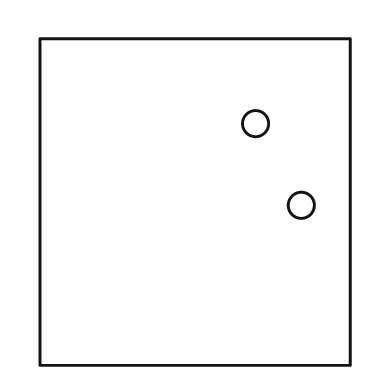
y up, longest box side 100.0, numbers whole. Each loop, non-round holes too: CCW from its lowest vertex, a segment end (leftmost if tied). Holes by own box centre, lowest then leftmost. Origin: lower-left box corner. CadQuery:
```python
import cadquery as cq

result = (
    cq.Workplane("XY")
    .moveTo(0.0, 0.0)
    .lineTo(95.0, 0.0)
    .lineTo(95.0, 100.0)
    .lineTo(0.0, 100.0)
    .close()
    .moveTo(80.0, 49.0)
    .circle(4.0)
    .moveTo(66.0, 74.0)
    .circle(4.0)
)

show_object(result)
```